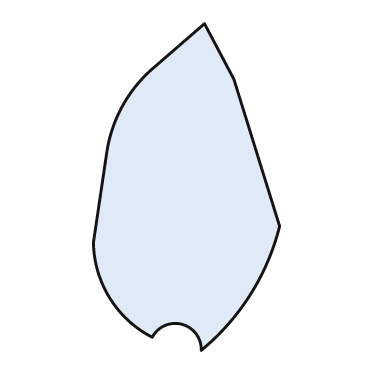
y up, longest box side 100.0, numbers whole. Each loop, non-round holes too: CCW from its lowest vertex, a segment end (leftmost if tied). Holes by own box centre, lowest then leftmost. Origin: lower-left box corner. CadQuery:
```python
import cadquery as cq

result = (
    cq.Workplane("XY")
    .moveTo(33.0, 0.0)
    .threePointArc((48.0, 17.0), (57.0, 38.0))
    .lineTo(43.0, 83.0)
    .lineTo(34.0, 100.0)
    .lineTo(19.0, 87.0)
    .threePointArc((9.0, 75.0), (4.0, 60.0))
    .lineTo(0.0, 33.0)
    .threePointArc((5.0, 16.0), (18.0, 4.0))
    .threePointArc((27.0, 8.0), (33.0, 0.0))
    .close()
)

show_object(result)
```